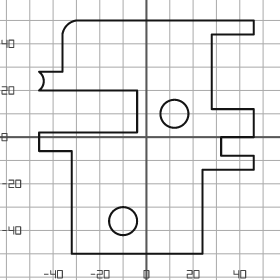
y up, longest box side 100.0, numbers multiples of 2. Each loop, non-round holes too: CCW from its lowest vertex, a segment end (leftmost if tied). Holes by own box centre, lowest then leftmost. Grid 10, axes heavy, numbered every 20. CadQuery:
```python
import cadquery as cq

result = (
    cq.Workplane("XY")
    .moveTo(-32.0, -50.0)
    .lineTo(24.0, -50.0)
    .lineTo(24.0, -14.0)
    .lineTo(46.0, -14.0)
    .lineTo(46.0, -8.0)
    .lineTo(32.0, -8.0)
    .lineTo(32.0, 0.0)
    .lineTo(46.0, 0.0)
    .lineTo(46.0, 12.0)
    .lineTo(28.0, 12.0)
    .lineTo(28.0, 44.0)
    .lineTo(46.0, 44.0)
    .lineTo(46.0, 50.0)
    .lineTo(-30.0, 50.0)
    .threePointArc((-34.0, 48.0), (-36.0, 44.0))
    .lineTo(-36.0, 28.0)
    .lineTo(-46.0, 28.0)
    .threePointArc((-44.0, 24.0), (-46.0, 20.0))
    .lineTo(-4.0, 20.0)
    .lineTo(-4.0, 2.0)
    .lineTo(-46.0, 2.0)
    .lineTo(-46.0, -6.0)
    .lineTo(-32.0, -6.0)
    .close()
    .moveTo(-10.0, -36.0)
    .circle(6.0)
    .moveTo(12.0, 10.0)
    .circle(6.0)
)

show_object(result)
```